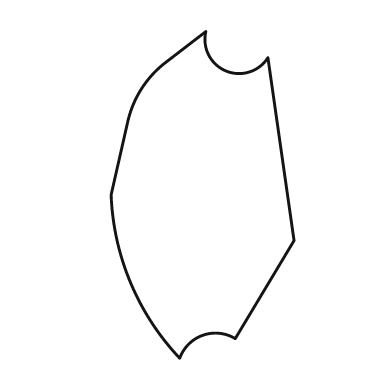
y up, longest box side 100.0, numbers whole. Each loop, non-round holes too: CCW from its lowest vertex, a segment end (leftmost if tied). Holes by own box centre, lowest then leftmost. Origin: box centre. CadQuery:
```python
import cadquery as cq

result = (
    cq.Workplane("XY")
    .moveTo(-7.0, -50.0)
    .threePointArc((0.0, -43.0), (10.0, -44.0))
    .lineTo(28.0, -14.0)
    .lineTo(20.0, 42.0)
    .threePointArc((7.0, 38.0), (1.0, 50.0))
    .lineTo(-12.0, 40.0)
    .threePointArc((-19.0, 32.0), (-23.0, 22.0))
    .lineTo(-28.0, 0.0)
    .threePointArc((-22.0, -27.0), (-7.0, -50.0))
    .close()
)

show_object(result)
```